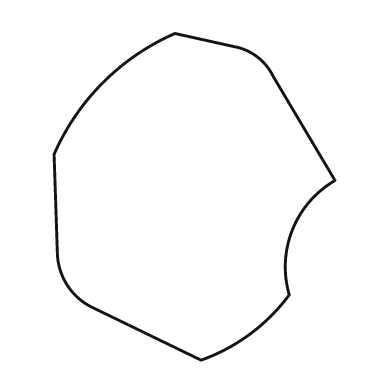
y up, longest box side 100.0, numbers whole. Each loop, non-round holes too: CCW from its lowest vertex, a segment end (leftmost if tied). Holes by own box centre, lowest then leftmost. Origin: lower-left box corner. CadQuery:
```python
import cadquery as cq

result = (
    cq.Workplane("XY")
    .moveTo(45.0, 0.0)
    .threePointArc((60.0, 8.0), (72.0, 20.0))
    .threePointArc((73.0, 40.0), (86.0, 55.0))
    .lineTo(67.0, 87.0)
    .threePointArc((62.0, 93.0), (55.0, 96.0))
    .lineTo(37.0, 100.0)
    .threePointArc((15.0, 85.0), (0.0, 63.0))
    .lineTo(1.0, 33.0)
    .threePointArc((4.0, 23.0), (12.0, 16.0))
    .close()
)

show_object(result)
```